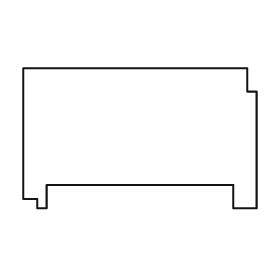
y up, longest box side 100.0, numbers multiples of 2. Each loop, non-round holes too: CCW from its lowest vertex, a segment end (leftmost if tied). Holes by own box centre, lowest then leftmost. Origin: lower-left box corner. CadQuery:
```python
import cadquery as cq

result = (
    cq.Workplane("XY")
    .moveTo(6.0, 0.0)
    .lineTo(10.0, 0.0)
    .lineTo(10.0, 10.0)
    .lineTo(90.0, 10.0)
    .lineTo(90.0, 0.0)
    .lineTo(100.0, 0.0)
    .lineTo(100.0, 50.0)
    .lineTo(96.0, 50.0)
    .lineTo(96.0, 60.0)
    .lineTo(0.0, 60.0)
    .lineTo(0.0, 4.0)
    .lineTo(6.0, 4.0)
    .close()
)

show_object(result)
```